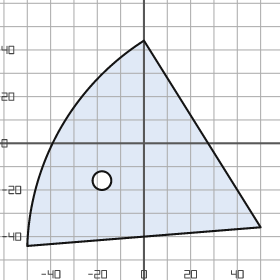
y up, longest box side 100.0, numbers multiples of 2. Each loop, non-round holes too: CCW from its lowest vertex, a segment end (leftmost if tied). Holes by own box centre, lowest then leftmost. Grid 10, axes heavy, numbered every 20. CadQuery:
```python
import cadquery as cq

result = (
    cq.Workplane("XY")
    .moveTo(-50.0, -44.0)
    .lineTo(50.0, -36.0)
    .lineTo(0.0, 44.0)
    .threePointArc((-36.0, 6.0), (-50.0, -44.0))
    .close()
    .moveTo(-18.0, -16.0)
    .circle(4.0)
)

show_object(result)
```